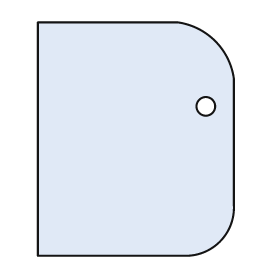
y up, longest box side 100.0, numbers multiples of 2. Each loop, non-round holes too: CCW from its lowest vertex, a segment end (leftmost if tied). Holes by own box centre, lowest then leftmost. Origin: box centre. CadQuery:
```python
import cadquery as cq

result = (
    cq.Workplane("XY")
    .moveTo(-42.0, -50.0)
    .lineTo(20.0, -50.0)
    .threePointArc((36.0, -44.0), (42.0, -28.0))
    .lineTo(42.0, 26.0)
    .threePointArc((34.0, 42.0), (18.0, 50.0))
    .lineTo(-42.0, 50.0)
    .close()
    .moveTo(30.0, 14.0)
    .circle(4.0)
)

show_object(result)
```